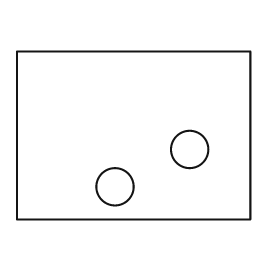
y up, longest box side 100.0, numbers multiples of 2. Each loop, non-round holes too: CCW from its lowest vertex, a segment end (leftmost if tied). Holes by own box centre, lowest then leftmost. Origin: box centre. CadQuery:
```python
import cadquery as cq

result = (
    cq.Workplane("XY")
    .moveTo(-50.0, -36.0)
    .lineTo(50.0, -36.0)
    .lineTo(50.0, 36.0)
    .lineTo(-50.0, 36.0)
    .close()
    .moveTo(-8.0, -22.0)
    .circle(8.0)
    .moveTo(24.0, -6.0)
    .circle(8.0)
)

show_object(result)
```